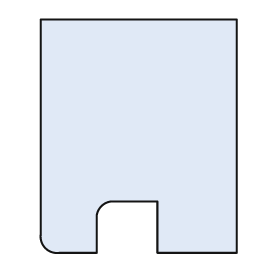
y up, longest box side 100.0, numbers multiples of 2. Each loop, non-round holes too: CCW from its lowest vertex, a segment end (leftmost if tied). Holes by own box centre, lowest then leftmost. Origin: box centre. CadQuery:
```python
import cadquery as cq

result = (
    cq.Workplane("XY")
    .moveTo(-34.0, -50.0)
    .lineTo(-18.0, -50.0)
    .lineTo(-18.0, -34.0)
    .threePointArc((-16.0, -30.0), (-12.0, -28.0))
    .lineTo(8.0, -28.0)
    .lineTo(8.0, -50.0)
    .lineTo(42.0, -50.0)
    .lineTo(42.0, 50.0)
    .lineTo(-42.0, 50.0)
    .lineTo(-42.0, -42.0)
    .threePointArc((-40.0, -48.0), (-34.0, -50.0))
    .close()
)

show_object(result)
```